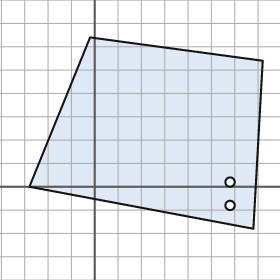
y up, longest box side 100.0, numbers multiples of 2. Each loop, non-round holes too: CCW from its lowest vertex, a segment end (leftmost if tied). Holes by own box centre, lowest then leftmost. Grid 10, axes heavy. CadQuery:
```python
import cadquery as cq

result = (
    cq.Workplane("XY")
    .moveTo(68.0, -18.0)
    .lineTo(72.0, 54.0)
    .lineTo(-2.0, 64.0)
    .lineTo(-28.0, 0.0)
    .close()
    .moveTo(58.0, -8.0)
    .circle(2.0)
    .moveTo(58.0, 2.0)
    .circle(2.0)
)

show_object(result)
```